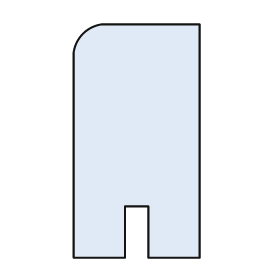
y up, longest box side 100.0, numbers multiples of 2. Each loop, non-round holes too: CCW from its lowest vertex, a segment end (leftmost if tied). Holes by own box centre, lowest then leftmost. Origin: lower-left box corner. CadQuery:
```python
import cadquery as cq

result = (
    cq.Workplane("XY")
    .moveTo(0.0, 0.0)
    .lineTo(22.0, 0.0)
    .lineTo(22.0, 22.0)
    .lineTo(32.0, 22.0)
    .lineTo(32.0, 0.0)
    .lineTo(54.0, 0.0)
    .lineTo(54.0, 100.0)
    .lineTo(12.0, 100.0)
    .threePointArc((4.0, 96.0), (0.0, 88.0))
    .close()
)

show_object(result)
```